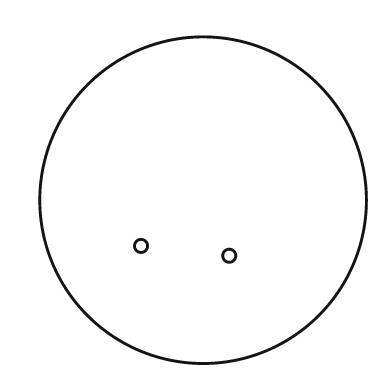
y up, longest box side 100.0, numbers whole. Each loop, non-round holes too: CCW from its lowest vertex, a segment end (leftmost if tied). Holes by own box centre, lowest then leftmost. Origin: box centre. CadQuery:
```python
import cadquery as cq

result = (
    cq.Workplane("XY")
    .moveTo(0.0, 0.0)
    .circle(50.0)
    .moveTo(8.0, -17.0)
    .circle(2.0)
    .moveTo(-19.0, -14.0)
    .circle(2.0)
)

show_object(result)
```